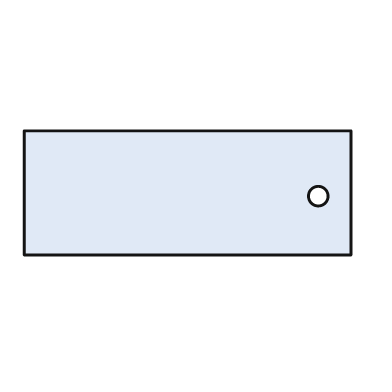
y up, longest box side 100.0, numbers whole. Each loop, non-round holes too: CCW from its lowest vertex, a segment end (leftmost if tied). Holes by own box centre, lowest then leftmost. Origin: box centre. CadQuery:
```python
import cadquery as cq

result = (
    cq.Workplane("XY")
    .moveTo(-50.0, -19.0)
    .lineTo(50.0, -19.0)
    .lineTo(50.0, 19.0)
    .lineTo(-50.0, 19.0)
    .close()
    .moveTo(40.0, -1.0)
    .circle(3.0)
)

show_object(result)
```